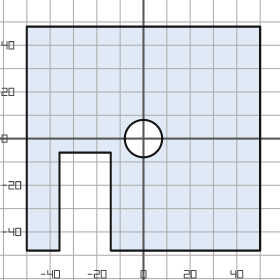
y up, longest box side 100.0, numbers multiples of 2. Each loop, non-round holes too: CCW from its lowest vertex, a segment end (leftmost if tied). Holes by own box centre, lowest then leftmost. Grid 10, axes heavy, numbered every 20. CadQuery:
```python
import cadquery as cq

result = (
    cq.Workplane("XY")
    .moveTo(-50.0, -48.0)
    .lineTo(-36.0, -48.0)
    .lineTo(-36.0, -6.0)
    .lineTo(-14.0, -6.0)
    .lineTo(-14.0, -48.0)
    .lineTo(50.0, -48.0)
    .lineTo(50.0, 48.0)
    .lineTo(-50.0, 48.0)
    .close()
    .moveTo(0.0, 0.0)
    .circle(8.0)
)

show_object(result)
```